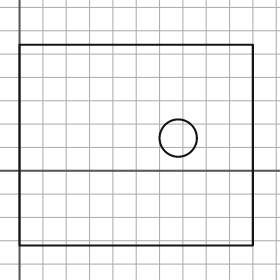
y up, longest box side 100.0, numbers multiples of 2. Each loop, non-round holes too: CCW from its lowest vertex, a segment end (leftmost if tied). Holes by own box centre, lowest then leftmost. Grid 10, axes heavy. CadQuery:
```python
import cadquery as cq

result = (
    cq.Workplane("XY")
    .moveTo(0.0, -32.0)
    .lineTo(100.0, -32.0)
    .lineTo(100.0, 54.0)
    .lineTo(0.0, 54.0)
    .close()
    .moveTo(68.0, 14.0)
    .circle(8.0)
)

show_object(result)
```